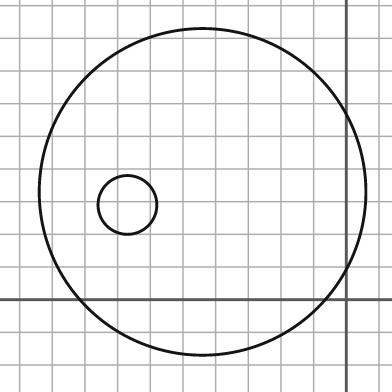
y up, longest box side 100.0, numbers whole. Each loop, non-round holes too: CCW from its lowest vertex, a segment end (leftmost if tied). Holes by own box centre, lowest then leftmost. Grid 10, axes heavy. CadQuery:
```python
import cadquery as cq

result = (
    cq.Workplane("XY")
    .moveTo(-44.0, 33.0)
    .circle(50.0)
    .moveTo(-67.0, 29.0)
    .circle(9.0)
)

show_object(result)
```